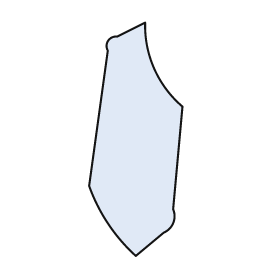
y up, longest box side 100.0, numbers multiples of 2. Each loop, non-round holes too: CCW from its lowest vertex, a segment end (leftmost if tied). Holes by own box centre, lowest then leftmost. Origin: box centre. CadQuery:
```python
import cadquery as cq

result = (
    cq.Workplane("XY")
    .moveTo(0.0, -50.0)
    .lineTo(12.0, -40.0)
    .threePointArc((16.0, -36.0), (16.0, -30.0))
    .lineTo(20.0, 14.0)
    .threePointArc((8.0, 30.0), (4.0, 50.0))
    .lineTo(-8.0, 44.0)
    .threePointArc((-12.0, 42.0), (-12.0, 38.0))
    .lineTo(-20.0, -20.0)
    .threePointArc((-12.0, -36.0), (0.0, -50.0))
    .close()
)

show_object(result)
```